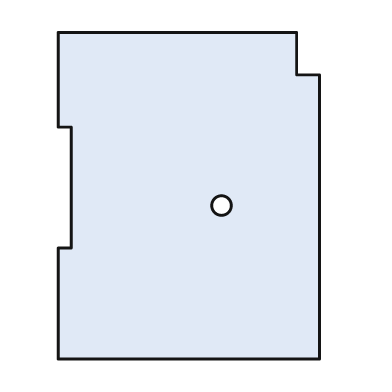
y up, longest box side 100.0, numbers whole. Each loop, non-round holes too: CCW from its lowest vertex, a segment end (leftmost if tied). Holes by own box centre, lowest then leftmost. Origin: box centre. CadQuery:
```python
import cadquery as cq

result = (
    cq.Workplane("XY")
    .moveTo(-40.0, -50.0)
    .lineTo(40.0, -50.0)
    .lineTo(40.0, 37.0)
    .lineTo(33.0, 37.0)
    .lineTo(33.0, 50.0)
    .lineTo(-40.0, 50.0)
    .lineTo(-40.0, 21.0)
    .lineTo(-36.0, 21.0)
    .lineTo(-36.0, -16.0)
    .lineTo(-40.0, -16.0)
    .close()
    .moveTo(10.0, -3.0)
    .circle(3.0)
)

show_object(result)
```